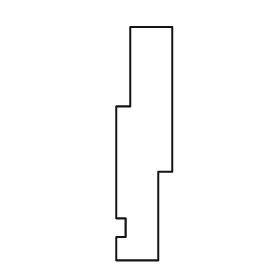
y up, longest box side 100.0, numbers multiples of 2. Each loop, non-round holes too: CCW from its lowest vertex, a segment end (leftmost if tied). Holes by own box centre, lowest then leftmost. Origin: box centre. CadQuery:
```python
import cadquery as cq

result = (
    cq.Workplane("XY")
    .moveTo(-12.0, -50.0)
    .lineTo(6.0, -50.0)
    .lineTo(6.0, -12.0)
    .lineTo(12.0, -12.0)
    .lineTo(12.0, 50.0)
    .lineTo(-6.0, 50.0)
    .lineTo(-6.0, 16.0)
    .lineTo(-12.0, 16.0)
    .lineTo(-12.0, -32.0)
    .lineTo(-8.0, -32.0)
    .lineTo(-8.0, -40.0)
    .lineTo(-12.0, -40.0)
    .close()
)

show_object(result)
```